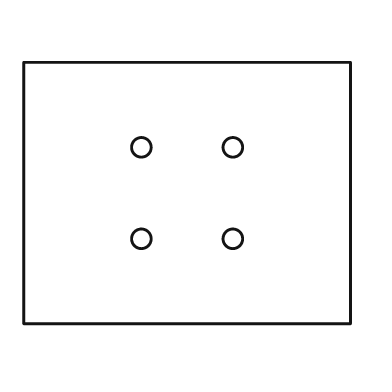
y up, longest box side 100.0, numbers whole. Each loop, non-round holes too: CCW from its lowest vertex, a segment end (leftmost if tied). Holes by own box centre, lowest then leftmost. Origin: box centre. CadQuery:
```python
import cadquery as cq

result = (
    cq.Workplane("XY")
    .moveTo(-50.0, -40.0)
    .lineTo(50.0, -40.0)
    .lineTo(50.0, 40.0)
    .lineTo(-50.0, 40.0)
    .close()
    .moveTo(-14.0, -14.0)
    .circle(3.0)
    .moveTo(14.0, -14.0)
    .circle(3.0)
    .moveTo(-14.0, 14.0)
    .circle(3.0)
    .moveTo(14.0, 14.0)
    .circle(3.0)
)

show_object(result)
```